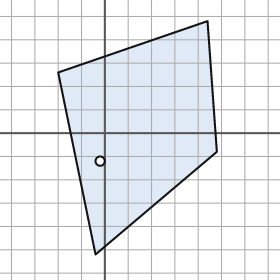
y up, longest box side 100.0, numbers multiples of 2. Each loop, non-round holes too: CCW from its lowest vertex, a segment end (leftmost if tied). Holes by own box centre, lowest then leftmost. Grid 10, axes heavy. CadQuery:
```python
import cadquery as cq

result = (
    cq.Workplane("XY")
    .moveTo(-4.0, -52.0)
    .lineTo(48.0, -8.0)
    .lineTo(44.0, 48.0)
    .lineTo(-20.0, 26.0)
    .close()
    .moveTo(-2.0, -12.0)
    .circle(2.0)
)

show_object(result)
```